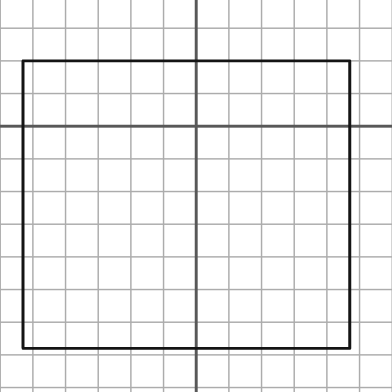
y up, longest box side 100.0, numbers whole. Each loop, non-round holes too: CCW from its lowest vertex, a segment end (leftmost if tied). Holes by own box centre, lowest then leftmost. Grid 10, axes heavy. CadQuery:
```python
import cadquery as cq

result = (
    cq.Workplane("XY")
    .moveTo(-53.0, -68.0)
    .lineTo(47.0, -68.0)
    .lineTo(47.0, 20.0)
    .lineTo(-53.0, 20.0)
    .close()
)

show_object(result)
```